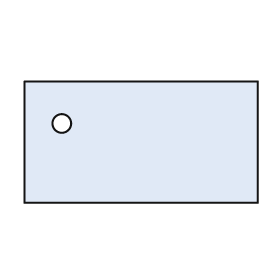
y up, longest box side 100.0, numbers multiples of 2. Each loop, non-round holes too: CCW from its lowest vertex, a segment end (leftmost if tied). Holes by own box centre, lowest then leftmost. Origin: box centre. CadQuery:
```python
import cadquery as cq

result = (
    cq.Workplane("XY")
    .moveTo(-50.0, -26.0)
    .lineTo(50.0, -26.0)
    .lineTo(50.0, 26.0)
    .lineTo(-50.0, 26.0)
    .close()
    .moveTo(-34.0, 8.0)
    .circle(4.0)
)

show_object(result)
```